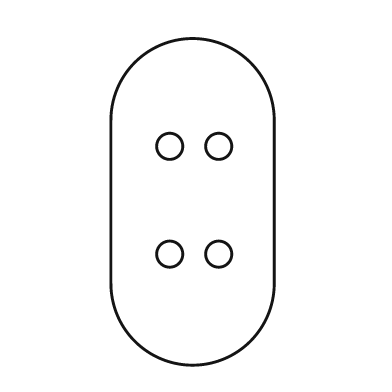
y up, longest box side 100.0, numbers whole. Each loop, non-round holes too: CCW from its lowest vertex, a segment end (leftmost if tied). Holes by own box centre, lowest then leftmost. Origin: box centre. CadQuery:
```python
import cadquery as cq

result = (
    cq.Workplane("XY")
    .moveTo(-25.0, -25.0)
    .threePointArc((0.0, -50.0), (25.0, -25.0))
    .lineTo(25.0, 25.0)
    .threePointArc((0.0, 50.0), (-25.0, 25.0))
    .close()
    .moveTo(-7.0, -16.0)
    .circle(4.0)
    .moveTo(8.0, -16.0)
    .circle(4.0)
    .moveTo(-7.0, 17.0)
    .circle(4.0)
    .moveTo(8.0, 17.0)
    .circle(4.0)
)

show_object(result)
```